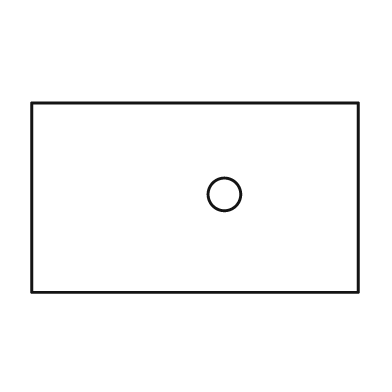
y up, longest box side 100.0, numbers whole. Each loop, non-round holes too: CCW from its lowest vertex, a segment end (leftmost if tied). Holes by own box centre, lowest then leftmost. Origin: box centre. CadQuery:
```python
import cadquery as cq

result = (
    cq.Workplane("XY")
    .moveTo(-50.0, -29.0)
    .lineTo(50.0, -29.0)
    .lineTo(50.0, 29.0)
    .lineTo(-50.0, 29.0)
    .close()
    .moveTo(9.0, 1.0)
    .circle(5.0)
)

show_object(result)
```